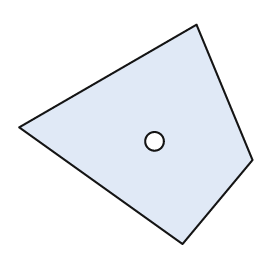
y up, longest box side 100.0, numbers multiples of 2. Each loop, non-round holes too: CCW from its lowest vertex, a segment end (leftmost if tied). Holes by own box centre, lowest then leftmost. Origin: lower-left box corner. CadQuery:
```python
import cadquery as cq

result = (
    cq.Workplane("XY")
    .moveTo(70.0, 0.0)
    .lineTo(100.0, 36.0)
    .lineTo(76.0, 94.0)
    .lineTo(0.0, 50.0)
    .close()
    .moveTo(58.0, 44.0)
    .circle(4.0)
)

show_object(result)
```